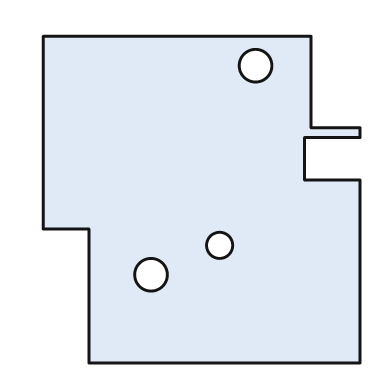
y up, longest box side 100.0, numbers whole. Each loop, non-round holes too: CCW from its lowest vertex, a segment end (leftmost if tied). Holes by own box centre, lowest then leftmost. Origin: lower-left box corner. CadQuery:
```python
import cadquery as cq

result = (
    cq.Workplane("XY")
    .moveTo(14.0, 0.0)
    .lineTo(97.0, 0.0)
    .lineTo(97.0, 56.0)
    .lineTo(80.0, 56.0)
    .lineTo(80.0, 69.0)
    .lineTo(97.0, 69.0)
    .lineTo(97.0, 72.0)
    .lineTo(82.0, 72.0)
    .lineTo(82.0, 100.0)
    .lineTo(0.0, 100.0)
    .lineTo(0.0, 41.0)
    .lineTo(14.0, 41.0)
    .close()
    .moveTo(33.0, 27.0)
    .circle(5.0)
    .moveTo(54.0, 36.0)
    .circle(4.0)
    .moveTo(65.0, 91.0)
    .circle(5.0)
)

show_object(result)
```